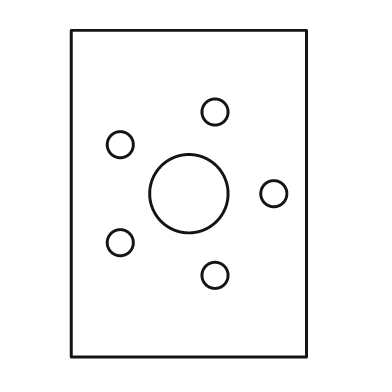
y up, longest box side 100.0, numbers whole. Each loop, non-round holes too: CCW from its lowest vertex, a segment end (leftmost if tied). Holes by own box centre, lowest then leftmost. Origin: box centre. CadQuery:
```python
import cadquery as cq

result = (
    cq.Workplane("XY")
    .moveTo(-36.0, -50.0)
    .lineTo(36.0, -50.0)
    .lineTo(36.0, 50.0)
    .lineTo(-36.0, 50.0)
    .close()
    .moveTo(8.0, -25.0)
    .circle(4.0)
    .moveTo(-21.0, -15.0)
    .circle(4.0)
    .moveTo(0.0, 0.0)
    .circle(12.0)
    .moveTo(26.0, 0.0)
    .circle(4.0)
    .moveTo(-21.0, 15.0)
    .circle(4.0)
    .moveTo(8.0, 25.0)
    .circle(4.0)
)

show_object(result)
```